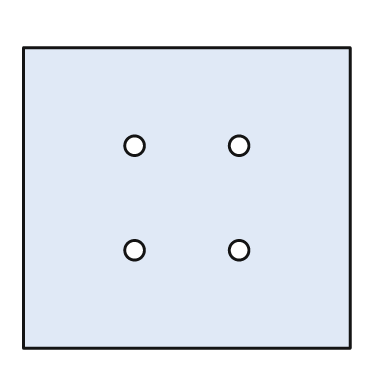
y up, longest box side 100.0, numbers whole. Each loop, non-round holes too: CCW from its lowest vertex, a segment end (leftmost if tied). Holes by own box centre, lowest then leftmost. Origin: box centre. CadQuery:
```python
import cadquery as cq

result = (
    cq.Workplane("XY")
    .moveTo(-50.0, -46.0)
    .lineTo(50.0, -46.0)
    .lineTo(50.0, 46.0)
    .lineTo(-50.0, 46.0)
    .close()
    .moveTo(-16.0, -16.0)
    .circle(3.0)
    .moveTo(16.0, -16.0)
    .circle(3.0)
    .moveTo(-16.0, 16.0)
    .circle(3.0)
    .moveTo(16.0, 16.0)
    .circle(3.0)
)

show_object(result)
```